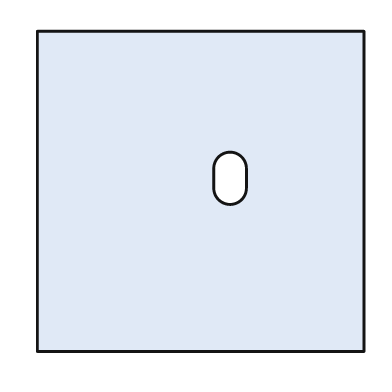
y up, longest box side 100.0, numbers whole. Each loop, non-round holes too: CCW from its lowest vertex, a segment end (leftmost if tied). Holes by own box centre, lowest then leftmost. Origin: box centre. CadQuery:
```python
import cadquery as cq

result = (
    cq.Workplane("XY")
    .moveTo(-50.0, -49.0)
    .lineTo(50.0, -49.0)
    .lineTo(50.0, 49.0)
    .lineTo(-50.0, 49.0)
    .close()
    .moveTo(4.0, 1.0)
    .threePointArc((9.0, -4.0), (14.0, 1.0))
    .lineTo(14.0, 7.0)
    .threePointArc((9.0, 12.0), (4.0, 7.0))
    .close()
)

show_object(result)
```